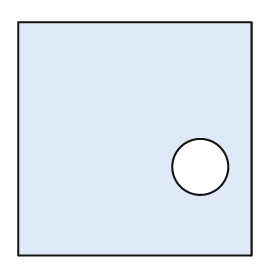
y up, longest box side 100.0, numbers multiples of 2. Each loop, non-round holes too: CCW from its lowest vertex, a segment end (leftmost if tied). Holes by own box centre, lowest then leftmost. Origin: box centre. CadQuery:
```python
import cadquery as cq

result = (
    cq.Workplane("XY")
    .moveTo(-50.0, -50.0)
    .lineTo(50.0, -50.0)
    .lineTo(50.0, 50.0)
    .lineTo(-50.0, 50.0)
    .close()
    .moveTo(28.0, -12.0)
    .circle(12.0)
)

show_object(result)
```